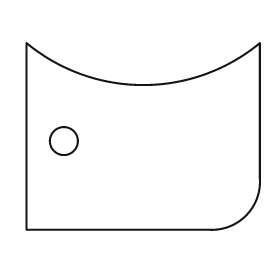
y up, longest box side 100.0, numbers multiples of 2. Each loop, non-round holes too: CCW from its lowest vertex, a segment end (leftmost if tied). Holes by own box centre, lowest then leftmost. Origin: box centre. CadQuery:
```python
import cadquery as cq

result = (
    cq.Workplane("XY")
    .moveTo(-50.0, -40.0)
    .lineTo(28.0, -40.0)
    .threePointArc((44.0, -34.0), (50.0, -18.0))
    .lineTo(50.0, 40.0)
    .threePointArc((0.0, 22.0), (-50.0, 40.0))
    .close()
    .moveTo(-34.0, -2.0)
    .circle(6.0)
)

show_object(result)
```